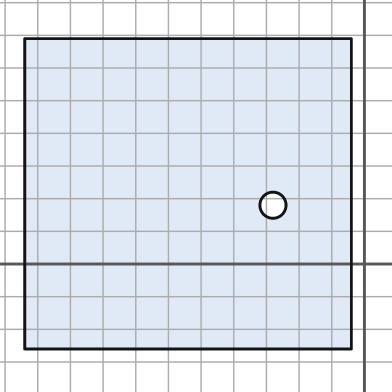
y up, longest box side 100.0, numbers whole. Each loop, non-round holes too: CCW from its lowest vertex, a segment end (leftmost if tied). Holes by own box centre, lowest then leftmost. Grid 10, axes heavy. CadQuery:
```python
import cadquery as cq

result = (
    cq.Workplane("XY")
    .moveTo(-104.0, -26.0)
    .lineTo(-4.0, -26.0)
    .lineTo(-4.0, 69.0)
    .lineTo(-104.0, 69.0)
    .close()
    .moveTo(-28.0, 18.0)
    .circle(4.0)
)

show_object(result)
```